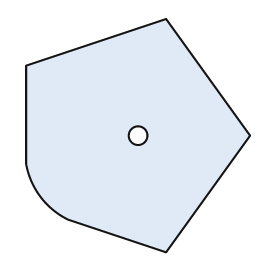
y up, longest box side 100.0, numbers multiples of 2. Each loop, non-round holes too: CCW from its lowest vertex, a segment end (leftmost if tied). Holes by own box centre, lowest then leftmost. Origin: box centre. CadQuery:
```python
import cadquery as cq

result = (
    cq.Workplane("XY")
    .moveTo(12.0, -50.0)
    .lineTo(48.0, 0.0)
    .lineTo(12.0, 50.0)
    .lineTo(-48.0, 30.0)
    .lineTo(-48.0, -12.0)
    .threePointArc((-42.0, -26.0), (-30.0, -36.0))
    .close()
    .moveTo(0.0, 0.0)
    .circle(4.0)
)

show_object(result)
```